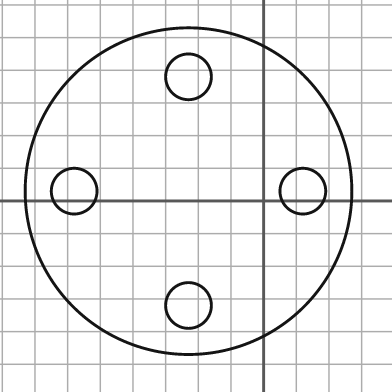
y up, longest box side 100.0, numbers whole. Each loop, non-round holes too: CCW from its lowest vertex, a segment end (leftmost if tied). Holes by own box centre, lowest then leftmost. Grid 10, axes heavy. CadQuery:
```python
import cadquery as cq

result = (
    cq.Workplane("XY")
    .moveTo(-23.0, 3.0)
    .circle(50.0)
    .moveTo(-23.0, -32.0)
    .circle(7.0)
    .moveTo(-58.0, 3.0)
    .circle(7.0)
    .moveTo(12.0, 3.0)
    .circle(7.0)
    .moveTo(-23.0, 38.0)
    .circle(7.0)
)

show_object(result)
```